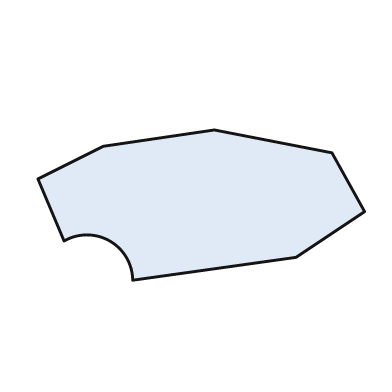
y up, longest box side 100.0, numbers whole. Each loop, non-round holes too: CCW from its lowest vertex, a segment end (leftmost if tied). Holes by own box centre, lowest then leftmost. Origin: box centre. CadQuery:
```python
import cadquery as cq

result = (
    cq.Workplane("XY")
    .moveTo(-21.0, -23.0)
    .lineTo(29.0, -16.0)
    .lineTo(50.0, -2.0)
    .lineTo(40.0, 16.0)
    .lineTo(4.0, 23.0)
    .lineTo(-30.0, 18.0)
    .lineTo(-50.0, 8.0)
    .lineTo(-42.0, -11.0)
    .threePointArc((-28.0, -11.0), (-21.0, -23.0))
    .close()
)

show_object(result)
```